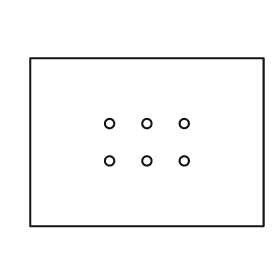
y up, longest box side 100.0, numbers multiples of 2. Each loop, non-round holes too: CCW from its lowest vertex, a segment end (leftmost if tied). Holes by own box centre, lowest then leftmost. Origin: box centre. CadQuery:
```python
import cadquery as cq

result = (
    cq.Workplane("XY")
    .moveTo(-50.0, -36.0)
    .lineTo(50.0, -36.0)
    .lineTo(50.0, 36.0)
    .lineTo(-50.0, 36.0)
    .close()
    .moveTo(-16.0, -8.0)
    .circle(2.0)
    .moveTo(0.0, -8.0)
    .circle(2.0)
    .moveTo(16.0, -8.0)
    .circle(2.0)
    .moveTo(-16.0, 8.0)
    .circle(2.0)
    .moveTo(0.0, 8.0)
    .circle(2.0)
    .moveTo(16.0, 8.0)
    .circle(2.0)
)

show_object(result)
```